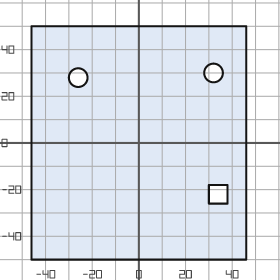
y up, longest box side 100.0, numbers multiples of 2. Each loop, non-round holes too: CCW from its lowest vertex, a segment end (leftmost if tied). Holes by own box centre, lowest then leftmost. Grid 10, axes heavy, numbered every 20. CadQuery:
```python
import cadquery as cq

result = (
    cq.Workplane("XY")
    .moveTo(-46.0, -50.0)
    .lineTo(46.0, -50.0)
    .lineTo(46.0, 50.0)
    .lineTo(-46.0, 50.0)
    .close()
    .moveTo(30.0, -26.0)
    .lineTo(38.0, -26.0)
    .lineTo(38.0, -18.0)
    .lineTo(30.0, -18.0)
    .close()
    .moveTo(-26.0, 28.0)
    .circle(4.0)
    .moveTo(32.0, 30.0)
    .circle(4.0)
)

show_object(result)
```